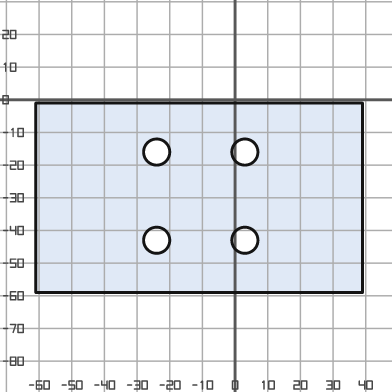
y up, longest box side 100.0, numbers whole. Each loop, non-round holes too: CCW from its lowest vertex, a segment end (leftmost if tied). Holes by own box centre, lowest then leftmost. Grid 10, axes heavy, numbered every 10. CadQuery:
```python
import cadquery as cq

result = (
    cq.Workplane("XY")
    .moveTo(-61.0, -59.0)
    .lineTo(39.0, -59.0)
    .lineTo(39.0, -1.0)
    .lineTo(-61.0, -1.0)
    .close()
    .moveTo(-24.0, -43.0)
    .circle(4.0)
    .moveTo(3.0, -43.0)
    .circle(4.0)
    .moveTo(-24.0, -16.0)
    .circle(4.0)
    .moveTo(3.0, -16.0)
    .circle(4.0)
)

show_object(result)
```